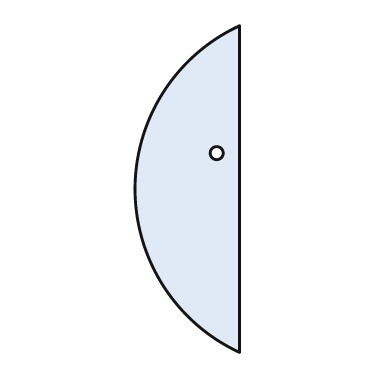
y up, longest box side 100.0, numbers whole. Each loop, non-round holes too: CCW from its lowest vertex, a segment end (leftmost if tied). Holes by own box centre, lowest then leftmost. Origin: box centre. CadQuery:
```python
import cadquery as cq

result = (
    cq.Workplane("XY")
    .moveTo(16.0, -50.0)
    .lineTo(16.0, 50.0)
    .threePointArc((-16.0, 0.0), (16.0, -50.0))
    .close()
    .moveTo(9.0, 11.0)
    .circle(2.0)
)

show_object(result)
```